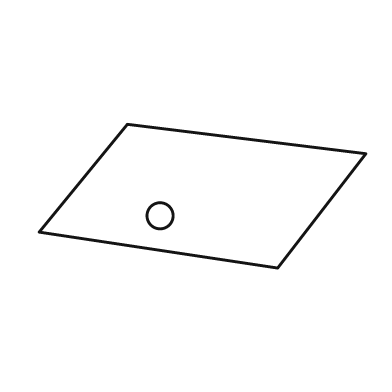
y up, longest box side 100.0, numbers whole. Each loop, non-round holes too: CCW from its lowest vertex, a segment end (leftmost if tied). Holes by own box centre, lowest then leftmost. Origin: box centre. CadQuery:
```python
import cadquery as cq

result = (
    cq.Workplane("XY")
    .moveTo(23.0, -22.0)
    .lineTo(50.0, 13.0)
    .lineTo(-23.0, 22.0)
    .lineTo(-50.0, -11.0)
    .close()
    .moveTo(-13.0, -6.0)
    .circle(4.0)
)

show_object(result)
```